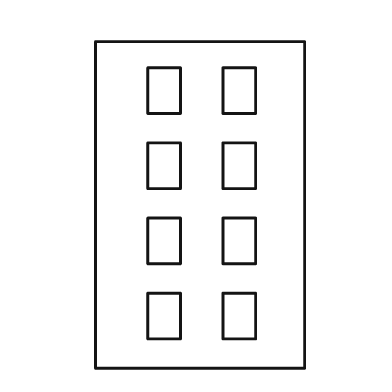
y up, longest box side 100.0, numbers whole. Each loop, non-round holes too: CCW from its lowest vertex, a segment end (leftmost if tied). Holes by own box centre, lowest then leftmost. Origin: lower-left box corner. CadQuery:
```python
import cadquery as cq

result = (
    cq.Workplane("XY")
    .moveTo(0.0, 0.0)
    .lineTo(64.0, 0.0)
    .lineTo(64.0, 100.0)
    .lineTo(0.0, 100.0)
    .close()
    .moveTo(16.0, 9.0)
    .lineTo(26.0, 9.0)
    .lineTo(26.0, 23.0)
    .lineTo(16.0, 23.0)
    .close()
    .moveTo(39.0, 9.0)
    .lineTo(49.0, 9.0)
    .lineTo(49.0, 23.0)
    .lineTo(39.0, 23.0)
    .close()
    .moveTo(16.0, 32.0)
    .lineTo(26.0, 32.0)
    .lineTo(26.0, 46.0)
    .lineTo(16.0, 46.0)
    .close()
    .moveTo(39.0, 32.0)
    .lineTo(49.0, 32.0)
    .lineTo(49.0, 46.0)
    .lineTo(39.0, 46.0)
    .close()
    .moveTo(16.0, 55.0)
    .lineTo(26.0, 55.0)
    .lineTo(26.0, 69.0)
    .lineTo(16.0, 69.0)
    .close()
    .moveTo(39.0, 55.0)
    .lineTo(49.0, 55.0)
    .lineTo(49.0, 69.0)
    .lineTo(39.0, 69.0)
    .close()
    .moveTo(16.0, 78.0)
    .lineTo(26.0, 78.0)
    .lineTo(26.0, 92.0)
    .lineTo(16.0, 92.0)
    .close()
    .moveTo(39.0, 78.0)
    .lineTo(49.0, 78.0)
    .lineTo(49.0, 92.0)
    .lineTo(39.0, 92.0)
    .close()
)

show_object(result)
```